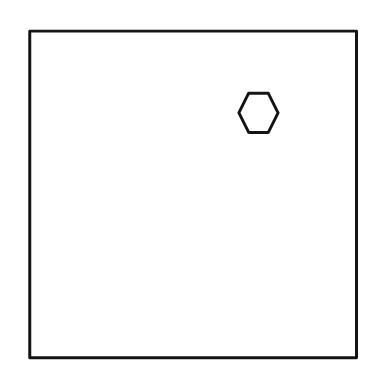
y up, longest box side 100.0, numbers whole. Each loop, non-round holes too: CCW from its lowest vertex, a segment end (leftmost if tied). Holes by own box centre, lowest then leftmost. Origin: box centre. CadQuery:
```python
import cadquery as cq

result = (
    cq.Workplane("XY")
    .moveTo(-50.0, -50.0)
    .lineTo(50.0, -50.0)
    .lineTo(50.0, 50.0)
    .lineTo(-50.0, 50.0)
    .close()
    .moveTo(17.0, 19.0)
    .lineTo(23.0, 19.0)
    .lineTo(26.0, 25.0)
    .lineTo(23.0, 31.0)
    .lineTo(17.0, 31.0)
    .lineTo(14.0, 25.0)
    .close()
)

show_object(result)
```